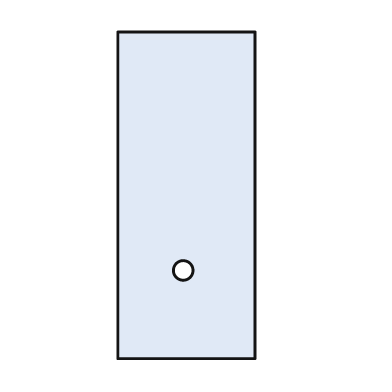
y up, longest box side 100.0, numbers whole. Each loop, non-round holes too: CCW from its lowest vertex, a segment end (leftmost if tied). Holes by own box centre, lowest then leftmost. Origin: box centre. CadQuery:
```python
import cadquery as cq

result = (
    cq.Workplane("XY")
    .moveTo(-21.0, -50.0)
    .lineTo(21.0, -50.0)
    .lineTo(21.0, 50.0)
    .lineTo(-21.0, 50.0)
    .close()
    .moveTo(-1.0, -23.0)
    .circle(3.0)
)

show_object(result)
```